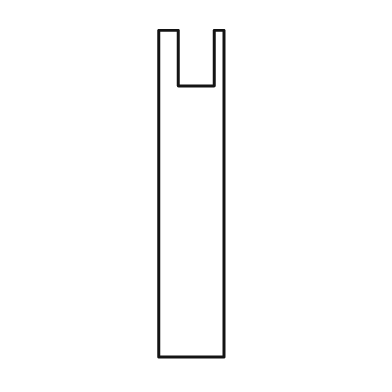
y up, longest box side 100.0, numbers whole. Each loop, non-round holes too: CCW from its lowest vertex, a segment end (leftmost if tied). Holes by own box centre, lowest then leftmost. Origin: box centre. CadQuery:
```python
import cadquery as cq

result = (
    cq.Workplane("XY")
    .moveTo(-10.0, -50.0)
    .lineTo(10.0, -50.0)
    .lineTo(10.0, 50.0)
    .lineTo(7.0, 50.0)
    .lineTo(7.0, 33.0)
    .lineTo(-4.0, 33.0)
    .lineTo(-4.0, 50.0)
    .lineTo(-10.0, 50.0)
    .close()
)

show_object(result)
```